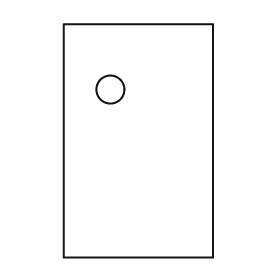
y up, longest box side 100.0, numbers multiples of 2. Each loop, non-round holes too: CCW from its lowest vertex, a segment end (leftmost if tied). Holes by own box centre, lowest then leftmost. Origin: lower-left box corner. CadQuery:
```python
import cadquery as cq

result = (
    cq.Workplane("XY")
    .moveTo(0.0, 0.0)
    .lineTo(64.0, 0.0)
    .lineTo(64.0, 100.0)
    .lineTo(0.0, 100.0)
    .close()
    .moveTo(20.0, 72.0)
    .circle(6.0)
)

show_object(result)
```